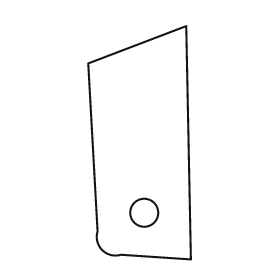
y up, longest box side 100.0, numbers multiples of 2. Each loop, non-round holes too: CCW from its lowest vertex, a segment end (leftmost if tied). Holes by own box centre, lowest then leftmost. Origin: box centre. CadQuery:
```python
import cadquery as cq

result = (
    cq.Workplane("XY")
    .moveTo(22.0, -50.0)
    .lineTo(20.0, 50.0)
    .lineTo(-22.0, 34.0)
    .lineTo(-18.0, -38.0)
    .threePointArc((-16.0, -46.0), (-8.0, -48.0))
    .close()
    .moveTo(2.0, -30.0)
    .circle(6.0)
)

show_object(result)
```